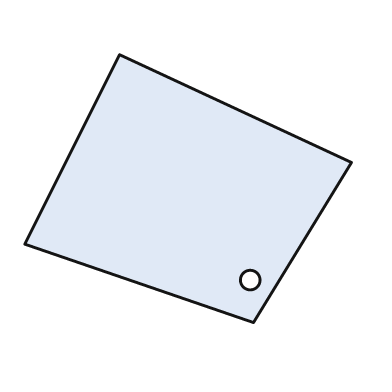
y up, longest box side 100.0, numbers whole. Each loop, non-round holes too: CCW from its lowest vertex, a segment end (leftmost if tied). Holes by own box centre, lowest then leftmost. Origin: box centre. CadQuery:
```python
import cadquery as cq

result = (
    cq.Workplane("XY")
    .moveTo(20.0, -41.0)
    .lineTo(50.0, 8.0)
    .lineTo(-21.0, 41.0)
    .lineTo(-50.0, -17.0)
    .close()
    .moveTo(19.0, -28.0)
    .circle(3.0)
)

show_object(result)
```